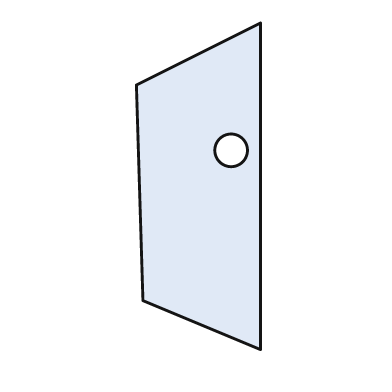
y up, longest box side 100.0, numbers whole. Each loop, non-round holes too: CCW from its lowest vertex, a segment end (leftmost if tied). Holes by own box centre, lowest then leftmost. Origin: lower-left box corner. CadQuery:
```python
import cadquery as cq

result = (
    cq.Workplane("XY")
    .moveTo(38.0, 0.0)
    .lineTo(38.0, 100.0)
    .lineTo(0.0, 81.0)
    .lineTo(2.0, 15.0)
    .close()
    .moveTo(29.0, 61.0)
    .circle(5.0)
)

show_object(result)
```